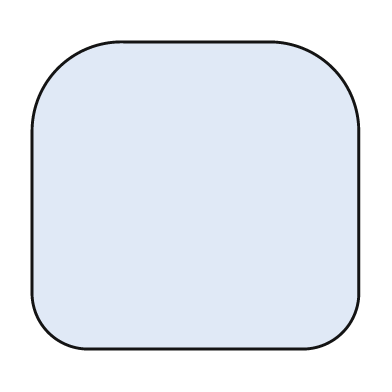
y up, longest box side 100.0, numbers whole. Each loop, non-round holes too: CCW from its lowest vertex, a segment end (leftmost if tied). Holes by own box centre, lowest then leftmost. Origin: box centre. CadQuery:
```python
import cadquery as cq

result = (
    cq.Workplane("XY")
    .moveTo(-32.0, -47.0)
    .lineTo(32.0, -47.0)
    .threePointArc((45.0, -42.0), (50.0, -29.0))
    .lineTo(50.0, 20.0)
    .threePointArc((42.0, 39.0), (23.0, 47.0))
    .lineTo(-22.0, 47.0)
    .threePointArc((-42.0, 39.0), (-50.0, 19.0))
    .lineTo(-50.0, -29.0)
    .threePointArc((-45.0, -42.0), (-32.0, -47.0))
    .close()
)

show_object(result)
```